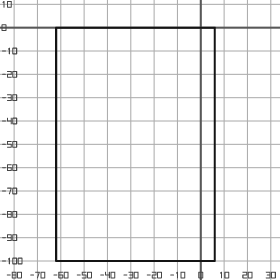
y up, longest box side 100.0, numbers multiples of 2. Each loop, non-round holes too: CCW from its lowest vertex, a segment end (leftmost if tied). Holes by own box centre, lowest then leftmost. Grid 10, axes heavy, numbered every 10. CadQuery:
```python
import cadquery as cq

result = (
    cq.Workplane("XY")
    .moveTo(-62.0, -100.0)
    .lineTo(6.0, -100.0)
    .lineTo(6.0, 0.0)
    .lineTo(-62.0, 0.0)
    .close()
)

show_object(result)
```